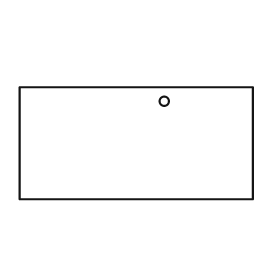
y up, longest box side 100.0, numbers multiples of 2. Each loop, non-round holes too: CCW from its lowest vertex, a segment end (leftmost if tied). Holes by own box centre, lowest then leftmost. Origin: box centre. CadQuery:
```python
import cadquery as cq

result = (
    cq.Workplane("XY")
    .moveTo(-50.0, -24.0)
    .lineTo(50.0, -24.0)
    .lineTo(50.0, 24.0)
    .lineTo(-50.0, 24.0)
    .close()
    .moveTo(12.0, 18.0)
    .circle(2.0)
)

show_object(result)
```